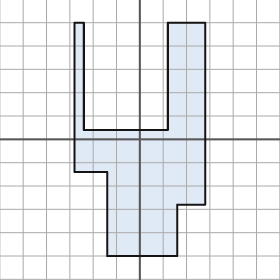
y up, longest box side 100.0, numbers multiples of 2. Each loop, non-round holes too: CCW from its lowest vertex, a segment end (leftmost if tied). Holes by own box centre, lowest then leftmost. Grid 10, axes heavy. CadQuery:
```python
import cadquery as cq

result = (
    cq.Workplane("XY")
    .moveTo(-14.0, -50.0)
    .lineTo(16.0, -50.0)
    .lineTo(16.0, -28.0)
    .lineTo(28.0, -28.0)
    .lineTo(28.0, 50.0)
    .lineTo(12.0, 50.0)
    .lineTo(12.0, 4.0)
    .lineTo(-24.0, 4.0)
    .lineTo(-24.0, 50.0)
    .lineTo(-28.0, 50.0)
    .lineTo(-28.0, -14.0)
    .lineTo(-14.0, -14.0)
    .close()
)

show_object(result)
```